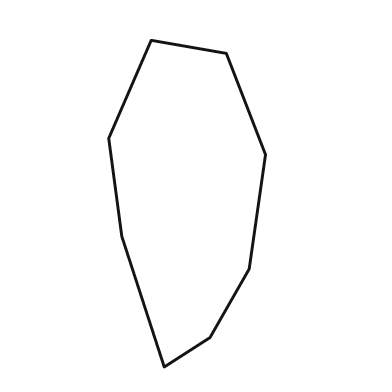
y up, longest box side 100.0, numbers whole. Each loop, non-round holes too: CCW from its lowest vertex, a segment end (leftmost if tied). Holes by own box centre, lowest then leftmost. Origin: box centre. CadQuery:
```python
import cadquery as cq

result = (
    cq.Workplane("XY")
    .moveTo(-7.0, -50.0)
    .lineTo(7.0, -41.0)
    .lineTo(19.0, -20.0)
    .lineTo(24.0, 15.0)
    .lineTo(12.0, 46.0)
    .lineTo(-11.0, 50.0)
    .lineTo(-24.0, 20.0)
    .lineTo(-20.0, -10.0)
    .close()
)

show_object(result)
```